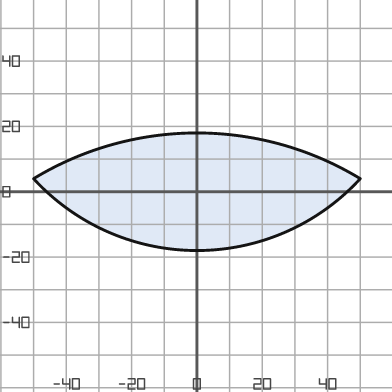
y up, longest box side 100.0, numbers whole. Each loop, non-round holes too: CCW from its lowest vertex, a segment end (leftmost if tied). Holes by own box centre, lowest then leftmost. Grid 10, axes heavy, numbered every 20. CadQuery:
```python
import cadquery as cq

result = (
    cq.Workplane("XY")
    .moveTo(-50.0, 4.0)
    .threePointArc((0.0, -18.0), (50.0, 4.0))
    .threePointArc((0.0, 18.0), (-50.0, 4.0))
    .close()
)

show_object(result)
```